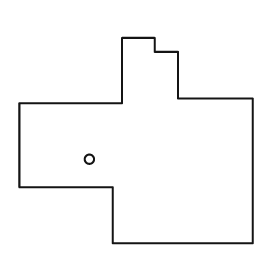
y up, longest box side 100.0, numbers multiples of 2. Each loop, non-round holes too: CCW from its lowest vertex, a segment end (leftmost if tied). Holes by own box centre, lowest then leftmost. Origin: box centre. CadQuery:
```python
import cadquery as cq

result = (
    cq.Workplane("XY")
    .moveTo(-10.0, -44.0)
    .lineTo(50.0, -44.0)
    .lineTo(50.0, 18.0)
    .lineTo(18.0, 18.0)
    .lineTo(18.0, 38.0)
    .lineTo(8.0, 38.0)
    .lineTo(8.0, 44.0)
    .lineTo(-6.0, 44.0)
    .lineTo(-6.0, 16.0)
    .lineTo(-50.0, 16.0)
    .lineTo(-50.0, -20.0)
    .lineTo(-10.0, -20.0)
    .close()
    .moveTo(-20.0, -8.0)
    .circle(2.0)
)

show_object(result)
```